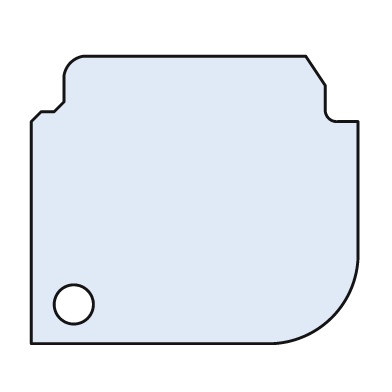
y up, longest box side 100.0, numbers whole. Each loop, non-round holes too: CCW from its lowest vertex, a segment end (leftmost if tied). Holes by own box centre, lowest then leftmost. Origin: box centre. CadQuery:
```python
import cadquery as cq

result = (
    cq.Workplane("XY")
    .moveTo(-50.0, -44.0)
    .lineTo(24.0, -44.0)
    .threePointArc((42.0, -36.0), (50.0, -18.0))
    .lineTo(50.0, 24.0)
    .lineTo(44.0, 24.0)
    .threePointArc((41.0, 25.0), (40.0, 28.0))
    .lineTo(40.0, 35.0)
    .lineTo(34.0, 44.0)
    .lineTo(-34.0, 44.0)
    .threePointArc((-38.0, 42.0), (-40.0, 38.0))
    .lineTo(-40.0, 30.0)
    .lineTo(-43.0, 27.0)
    .lineTo(-47.0, 27.0)
    .lineTo(-50.0, 24.0)
    .close()
    .moveTo(-37.0, -32.0)
    .circle(6.0)
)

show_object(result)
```